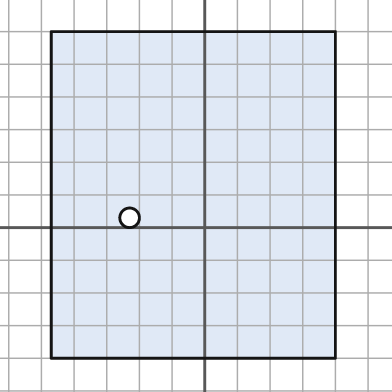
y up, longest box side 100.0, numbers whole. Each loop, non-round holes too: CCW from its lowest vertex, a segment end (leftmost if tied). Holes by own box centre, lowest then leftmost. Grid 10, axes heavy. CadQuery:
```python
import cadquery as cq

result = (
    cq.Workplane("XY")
    .moveTo(-47.0, -40.0)
    .lineTo(40.0, -40.0)
    .lineTo(40.0, 60.0)
    .lineTo(-47.0, 60.0)
    .close()
    .moveTo(-23.0, 3.0)
    .circle(3.0)
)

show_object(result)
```